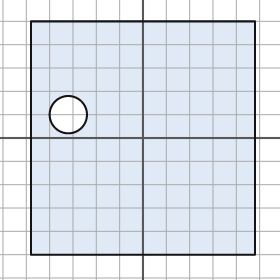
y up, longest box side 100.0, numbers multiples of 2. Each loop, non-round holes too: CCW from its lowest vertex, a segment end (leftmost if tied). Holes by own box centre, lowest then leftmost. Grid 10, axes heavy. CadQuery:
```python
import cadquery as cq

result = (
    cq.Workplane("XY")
    .moveTo(-48.0, -50.0)
    .lineTo(48.0, -50.0)
    .lineTo(48.0, 50.0)
    .lineTo(-48.0, 50.0)
    .close()
    .moveTo(-32.0, 10.0)
    .circle(8.0)
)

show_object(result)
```